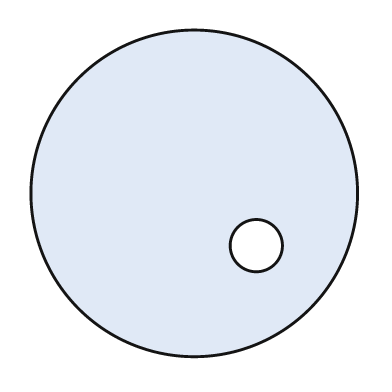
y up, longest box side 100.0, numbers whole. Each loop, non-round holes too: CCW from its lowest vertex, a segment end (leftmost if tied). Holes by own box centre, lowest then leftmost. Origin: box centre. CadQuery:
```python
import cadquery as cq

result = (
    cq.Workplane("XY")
    .moveTo(0.0, 0.0)
    .circle(50.0)
    .moveTo(19.0, -16.0)
    .circle(8.0)
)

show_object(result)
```